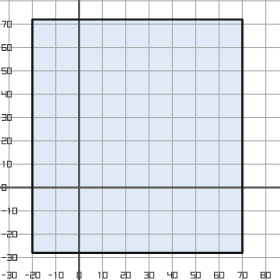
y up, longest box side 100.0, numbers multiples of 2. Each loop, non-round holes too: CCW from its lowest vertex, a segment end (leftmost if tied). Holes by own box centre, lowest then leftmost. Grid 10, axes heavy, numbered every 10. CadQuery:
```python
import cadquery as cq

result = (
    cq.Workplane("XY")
    .moveTo(-20.0, -28.0)
    .lineTo(70.0, -28.0)
    .lineTo(70.0, 72.0)
    .lineTo(-20.0, 72.0)
    .close()
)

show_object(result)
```